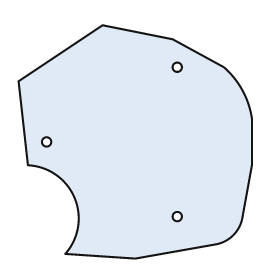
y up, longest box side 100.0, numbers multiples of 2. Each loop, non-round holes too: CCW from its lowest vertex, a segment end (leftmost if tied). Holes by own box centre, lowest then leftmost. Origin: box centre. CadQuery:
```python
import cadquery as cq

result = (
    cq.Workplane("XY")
    .moveTo(0.0, -50.0)
    .lineTo(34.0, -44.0)
    .threePointArc((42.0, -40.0), (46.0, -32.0))
    .lineTo(50.0, -10.0)
    .lineTo(50.0, 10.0)
    .threePointArc((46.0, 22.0), (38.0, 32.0))
    .lineTo(16.0, 44.0)
    .lineTo(-14.0, 50.0)
    .lineTo(-50.0, 26.0)
    .lineTo(-46.0, -10.0)
    .threePointArc((-26.0, -24.0), (-30.0, -48.0))
    .close()
    .moveTo(18.0, -32.0)
    .circle(2.0)
    .moveTo(-38.0, 0.0)
    .circle(2.0)
    .moveTo(18.0, 32.0)
    .circle(2.0)
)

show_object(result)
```